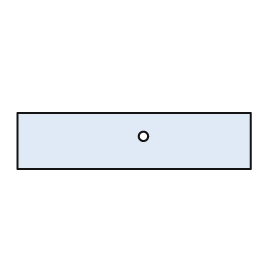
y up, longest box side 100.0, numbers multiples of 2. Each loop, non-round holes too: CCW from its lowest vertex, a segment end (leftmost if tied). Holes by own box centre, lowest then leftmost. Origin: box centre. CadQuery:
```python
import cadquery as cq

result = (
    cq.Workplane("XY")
    .moveTo(-50.0, -12.0)
    .lineTo(50.0, -12.0)
    .lineTo(50.0, 12.0)
    .lineTo(-50.0, 12.0)
    .close()
    .moveTo(4.0, 2.0)
    .circle(2.0)
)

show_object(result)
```